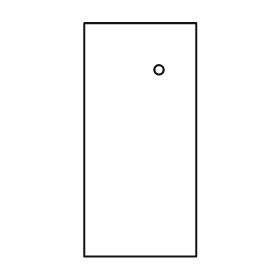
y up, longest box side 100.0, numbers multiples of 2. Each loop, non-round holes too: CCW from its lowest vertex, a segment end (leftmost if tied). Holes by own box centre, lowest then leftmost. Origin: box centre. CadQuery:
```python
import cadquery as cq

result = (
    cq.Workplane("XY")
    .moveTo(-24.0, -50.0)
    .lineTo(24.0, -50.0)
    .lineTo(24.0, 50.0)
    .lineTo(-24.0, 50.0)
    .close()
    .moveTo(8.0, 30.0)
    .circle(2.0)
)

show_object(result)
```